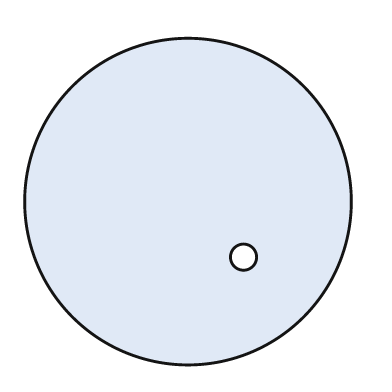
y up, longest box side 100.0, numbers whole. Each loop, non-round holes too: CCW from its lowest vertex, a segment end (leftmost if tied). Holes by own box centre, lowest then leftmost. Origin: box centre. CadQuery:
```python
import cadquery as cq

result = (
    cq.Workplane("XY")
    .moveTo(0.0, 0.0)
    .circle(50.0)
    .moveTo(17.0, -17.0)
    .circle(4.0)
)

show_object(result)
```